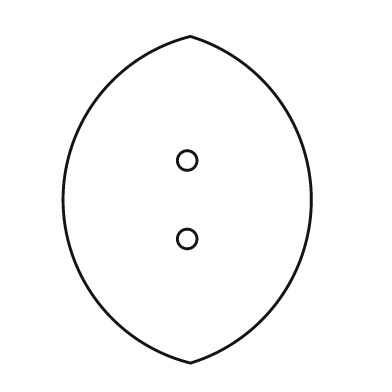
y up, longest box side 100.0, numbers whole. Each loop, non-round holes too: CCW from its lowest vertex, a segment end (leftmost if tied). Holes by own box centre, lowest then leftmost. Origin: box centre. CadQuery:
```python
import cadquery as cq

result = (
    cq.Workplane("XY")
    .moveTo(1.0, -50.0)
    .threePointArc((38.0, 0.0), (1.0, 50.0))
    .threePointArc((-38.0, 0.0), (1.0, -50.0))
    .close()
    .moveTo(0.0, -12.0)
    .circle(3.0)
    .moveTo(0.0, 12.0)
    .circle(3.0)
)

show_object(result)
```